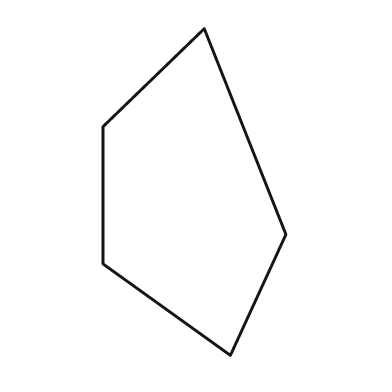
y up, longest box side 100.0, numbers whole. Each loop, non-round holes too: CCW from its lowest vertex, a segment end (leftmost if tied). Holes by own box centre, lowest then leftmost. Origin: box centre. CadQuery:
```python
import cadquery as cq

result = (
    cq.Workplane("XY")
    .moveTo(11.0, -50.0)
    .lineTo(28.0, -13.0)
    .lineTo(3.0, 50.0)
    .lineTo(-28.0, 20.0)
    .lineTo(-28.0, -22.0)
    .close()
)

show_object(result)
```